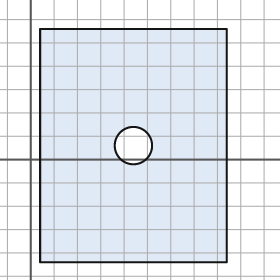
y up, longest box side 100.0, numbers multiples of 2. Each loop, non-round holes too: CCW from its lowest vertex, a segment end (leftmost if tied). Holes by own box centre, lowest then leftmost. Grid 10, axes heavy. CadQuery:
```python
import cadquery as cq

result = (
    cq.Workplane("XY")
    .moveTo(4.0, -44.0)
    .lineTo(84.0, -44.0)
    .lineTo(84.0, 56.0)
    .lineTo(4.0, 56.0)
    .close()
    .moveTo(44.0, 6.0)
    .circle(8.0)
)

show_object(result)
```